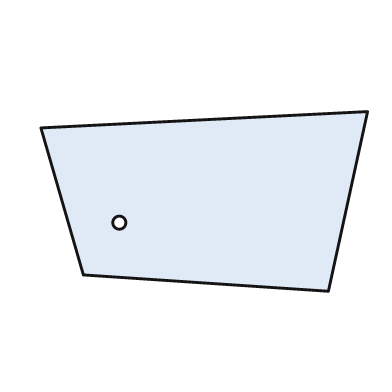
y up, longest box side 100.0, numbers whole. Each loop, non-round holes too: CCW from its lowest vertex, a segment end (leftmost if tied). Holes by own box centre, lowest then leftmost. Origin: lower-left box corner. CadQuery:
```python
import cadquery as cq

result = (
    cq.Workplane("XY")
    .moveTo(88.0, 0.0)
    .lineTo(100.0, 55.0)
    .lineTo(0.0, 50.0)
    .lineTo(13.0, 5.0)
    .close()
    .moveTo(24.0, 21.0)
    .circle(2.0)
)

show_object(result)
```